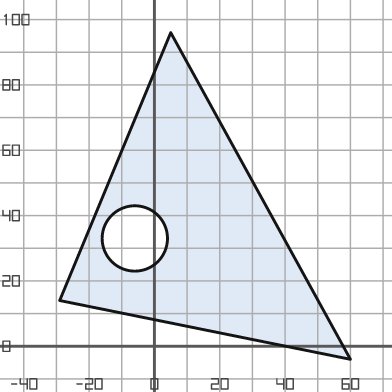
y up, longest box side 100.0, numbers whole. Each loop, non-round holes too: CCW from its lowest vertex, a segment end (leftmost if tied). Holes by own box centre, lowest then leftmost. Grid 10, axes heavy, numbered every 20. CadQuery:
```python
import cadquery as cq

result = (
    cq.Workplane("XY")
    .moveTo(60.0, -4.0)
    .lineTo(5.0, 96.0)
    .lineTo(-29.0, 14.0)
    .close()
    .moveTo(-6.0, 33.0)
    .circle(10.0)
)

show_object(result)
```